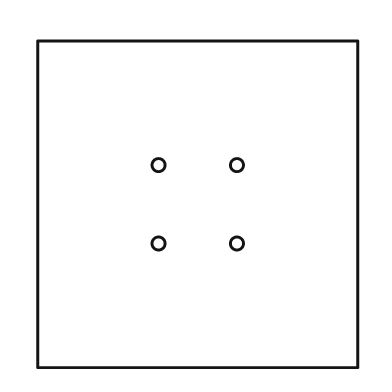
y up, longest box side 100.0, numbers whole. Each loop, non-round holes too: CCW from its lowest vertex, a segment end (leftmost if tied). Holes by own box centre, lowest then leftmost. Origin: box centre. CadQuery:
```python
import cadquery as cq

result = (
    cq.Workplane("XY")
    .moveTo(-49.0, -50.0)
    .lineTo(49.0, -50.0)
    .lineTo(49.0, 50.0)
    .lineTo(-49.0, 50.0)
    .close()
    .moveTo(-12.0, -12.0)
    .circle(2.0)
    .moveTo(12.0, -12.0)
    .circle(2.0)
    .moveTo(-12.0, 12.0)
    .circle(2.0)
    .moveTo(12.0, 12.0)
    .circle(2.0)
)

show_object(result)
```